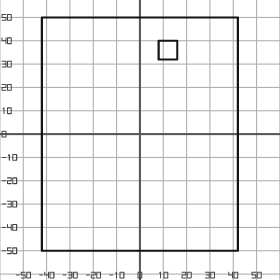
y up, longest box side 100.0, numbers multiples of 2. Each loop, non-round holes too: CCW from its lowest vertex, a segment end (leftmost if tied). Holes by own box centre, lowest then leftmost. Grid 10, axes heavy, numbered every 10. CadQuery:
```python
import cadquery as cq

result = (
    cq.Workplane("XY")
    .moveTo(-42.0, -50.0)
    .lineTo(42.0, -50.0)
    .lineTo(42.0, 50.0)
    .lineTo(-42.0, 50.0)
    .close()
    .moveTo(8.0, 32.0)
    .lineTo(16.0, 32.0)
    .lineTo(16.0, 40.0)
    .lineTo(8.0, 40.0)
    .close()
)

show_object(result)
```